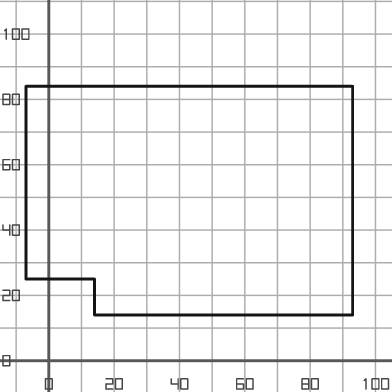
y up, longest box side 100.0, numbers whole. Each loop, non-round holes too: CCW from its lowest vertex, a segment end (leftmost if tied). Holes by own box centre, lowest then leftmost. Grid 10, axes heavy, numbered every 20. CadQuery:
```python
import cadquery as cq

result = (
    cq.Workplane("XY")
    .moveTo(14.0, 14.0)
    .lineTo(93.0, 14.0)
    .lineTo(93.0, 84.0)
    .lineTo(-7.0, 84.0)
    .lineTo(-7.0, 25.0)
    .lineTo(14.0, 25.0)
    .close()
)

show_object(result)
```